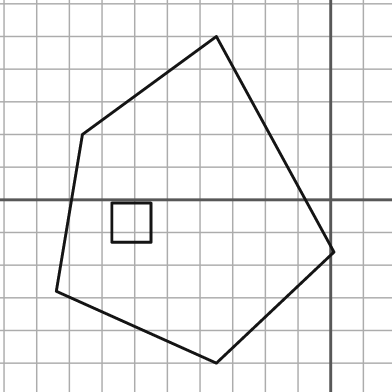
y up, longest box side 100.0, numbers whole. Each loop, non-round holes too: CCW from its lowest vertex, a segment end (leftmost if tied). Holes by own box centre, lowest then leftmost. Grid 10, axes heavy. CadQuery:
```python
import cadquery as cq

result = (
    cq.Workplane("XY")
    .moveTo(-35.0, -50.0)
    .lineTo(1.0, -16.0)
    .lineTo(-35.0, 50.0)
    .lineTo(-76.0, 20.0)
    .lineTo(-84.0, -28.0)
    .close()
    .moveTo(-67.0, -13.0)
    .lineTo(-55.0, -13.0)
    .lineTo(-55.0, -1.0)
    .lineTo(-67.0, -1.0)
    .close()
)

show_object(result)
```